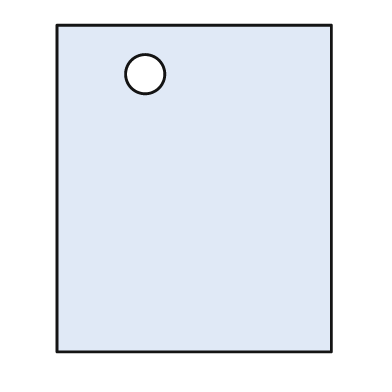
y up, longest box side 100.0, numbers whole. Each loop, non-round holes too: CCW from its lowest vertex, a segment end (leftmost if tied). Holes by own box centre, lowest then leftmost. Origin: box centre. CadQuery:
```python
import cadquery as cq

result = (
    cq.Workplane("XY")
    .moveTo(-42.0, -50.0)
    .lineTo(42.0, -50.0)
    .lineTo(42.0, 50.0)
    .lineTo(-42.0, 50.0)
    .close()
    .moveTo(-15.0, 35.0)
    .circle(6.0)
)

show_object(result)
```